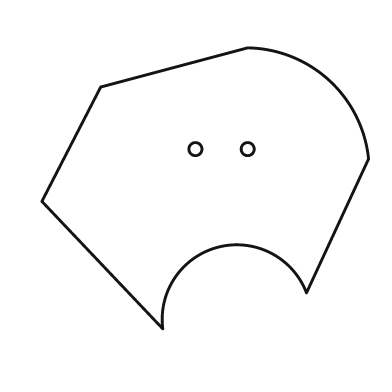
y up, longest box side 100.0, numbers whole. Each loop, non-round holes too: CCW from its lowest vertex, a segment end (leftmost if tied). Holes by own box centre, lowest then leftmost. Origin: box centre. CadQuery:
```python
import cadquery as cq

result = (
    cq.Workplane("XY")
    .moveTo(-13.0, -43.0)
    .threePointArc((4.0, -18.0), (31.0, -32.0))
    .lineTo(50.0, 9.0)
    .threePointArc((38.0, 33.0), (13.0, 43.0))
    .lineTo(-32.0, 31.0)
    .lineTo(-50.0, -4.0)
    .close()
    .moveTo(-3.0, 12.0)
    .circle(2.0)
    .moveTo(13.0, 12.0)
    .circle(2.0)
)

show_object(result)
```